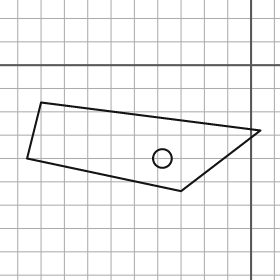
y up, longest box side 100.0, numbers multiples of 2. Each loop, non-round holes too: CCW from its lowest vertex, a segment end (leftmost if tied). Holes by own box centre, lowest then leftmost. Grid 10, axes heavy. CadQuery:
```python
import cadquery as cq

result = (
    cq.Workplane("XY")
    .moveTo(-30.0, -54.0)
    .lineTo(4.0, -28.0)
    .lineTo(-90.0, -16.0)
    .lineTo(-96.0, -40.0)
    .close()
    .moveTo(-38.0, -40.0)
    .circle(4.0)
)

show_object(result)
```